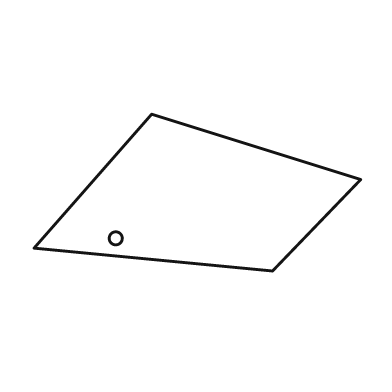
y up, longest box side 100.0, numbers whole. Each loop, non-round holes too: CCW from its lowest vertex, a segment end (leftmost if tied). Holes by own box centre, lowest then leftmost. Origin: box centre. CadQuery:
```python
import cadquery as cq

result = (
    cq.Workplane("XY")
    .moveTo(23.0, -24.0)
    .lineTo(50.0, 4.0)
    .lineTo(-14.0, 24.0)
    .lineTo(-50.0, -17.0)
    .close()
    .moveTo(-25.0, -14.0)
    .circle(2.0)
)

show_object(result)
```